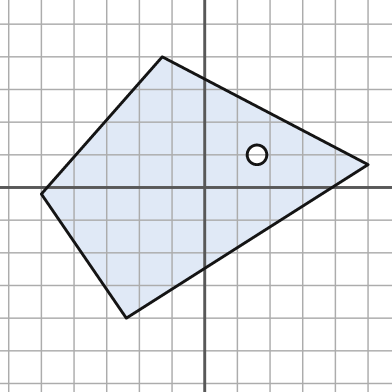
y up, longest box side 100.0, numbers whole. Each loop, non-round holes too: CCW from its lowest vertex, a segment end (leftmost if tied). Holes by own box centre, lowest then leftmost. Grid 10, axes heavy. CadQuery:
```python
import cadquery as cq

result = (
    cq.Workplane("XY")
    .moveTo(-24.0, -40.0)
    .lineTo(50.0, 7.0)
    .lineTo(-13.0, 40.0)
    .lineTo(-50.0, -2.0)
    .close()
    .moveTo(16.0, 10.0)
    .circle(3.0)
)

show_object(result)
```